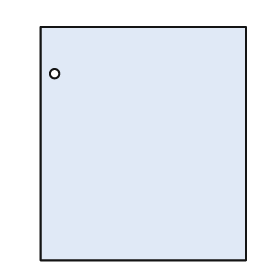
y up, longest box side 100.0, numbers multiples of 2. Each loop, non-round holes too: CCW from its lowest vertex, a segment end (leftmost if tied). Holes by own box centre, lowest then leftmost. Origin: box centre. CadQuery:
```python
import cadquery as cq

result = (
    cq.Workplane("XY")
    .moveTo(-44.0, -50.0)
    .lineTo(44.0, -50.0)
    .lineTo(44.0, 50.0)
    .lineTo(-44.0, 50.0)
    .close()
    .moveTo(-38.0, 30.0)
    .circle(2.0)
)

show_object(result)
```